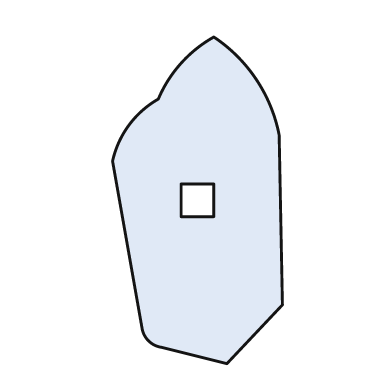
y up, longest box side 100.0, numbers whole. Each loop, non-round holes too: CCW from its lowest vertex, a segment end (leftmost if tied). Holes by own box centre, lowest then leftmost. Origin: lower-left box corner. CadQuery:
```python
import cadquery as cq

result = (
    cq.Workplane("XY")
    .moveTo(35.0, 0.0)
    .lineTo(52.0, 18.0)
    .lineTo(51.0, 70.0)
    .threePointArc((44.0, 87.0), (31.0, 100.0))
    .threePointArc((21.0, 92.0), (14.0, 81.0))
    .threePointArc((5.0, 73.0), (0.0, 62.0))
    .lineTo(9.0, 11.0)
    .threePointArc((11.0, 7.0), (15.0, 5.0))
    .close()
    .moveTo(21.0, 45.0)
    .lineTo(31.0, 45.0)
    .lineTo(31.0, 55.0)
    .lineTo(21.0, 55.0)
    .close()
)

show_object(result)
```